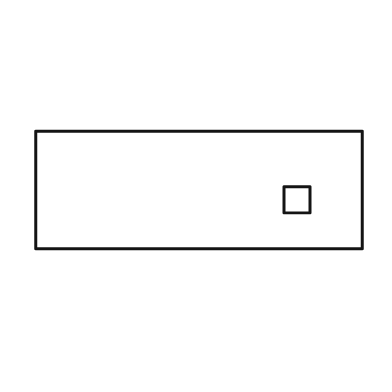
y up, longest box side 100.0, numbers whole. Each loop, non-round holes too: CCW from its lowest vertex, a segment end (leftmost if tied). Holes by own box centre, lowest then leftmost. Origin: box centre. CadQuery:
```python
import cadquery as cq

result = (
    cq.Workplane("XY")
    .moveTo(-50.0, -18.0)
    .lineTo(50.0, -18.0)
    .lineTo(50.0, 18.0)
    .lineTo(-50.0, 18.0)
    .close()
    .moveTo(26.0, -7.0)
    .lineTo(34.0, -7.0)
    .lineTo(34.0, 1.0)
    .lineTo(26.0, 1.0)
    .close()
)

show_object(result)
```